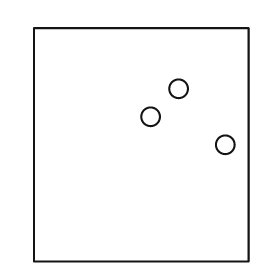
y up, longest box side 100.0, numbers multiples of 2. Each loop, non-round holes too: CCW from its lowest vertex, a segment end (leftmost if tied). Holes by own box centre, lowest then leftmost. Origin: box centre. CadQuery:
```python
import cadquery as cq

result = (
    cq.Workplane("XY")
    .moveTo(-46.0, -50.0)
    .lineTo(46.0, -50.0)
    .lineTo(46.0, 50.0)
    .lineTo(-46.0, 50.0)
    .close()
    .moveTo(36.0, 0.0)
    .circle(4.0)
    .moveTo(4.0, 12.0)
    .circle(4.0)
    .moveTo(16.0, 24.0)
    .circle(4.0)
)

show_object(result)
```